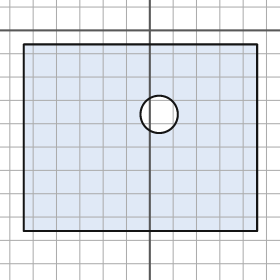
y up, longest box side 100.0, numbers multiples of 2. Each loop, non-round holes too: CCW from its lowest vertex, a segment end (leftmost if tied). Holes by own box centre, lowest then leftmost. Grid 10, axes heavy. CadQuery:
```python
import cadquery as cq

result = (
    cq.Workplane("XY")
    .moveTo(-54.0, -86.0)
    .lineTo(46.0, -86.0)
    .lineTo(46.0, -6.0)
    .lineTo(-54.0, -6.0)
    .close()
    .moveTo(4.0, -36.0)
    .circle(8.0)
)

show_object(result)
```